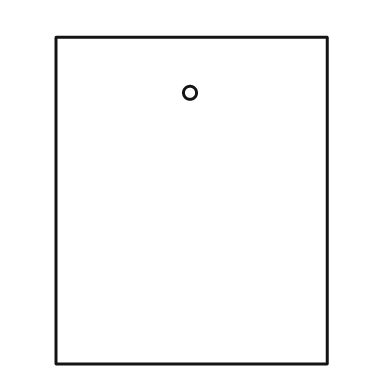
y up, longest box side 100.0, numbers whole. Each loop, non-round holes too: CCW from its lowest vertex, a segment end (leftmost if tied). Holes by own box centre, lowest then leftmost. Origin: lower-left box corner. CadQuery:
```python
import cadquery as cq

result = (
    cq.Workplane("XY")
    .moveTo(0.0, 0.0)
    .lineTo(83.0, 0.0)
    .lineTo(83.0, 100.0)
    .lineTo(0.0, 100.0)
    .close()
    .moveTo(41.0, 83.0)
    .circle(2.0)
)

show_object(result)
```